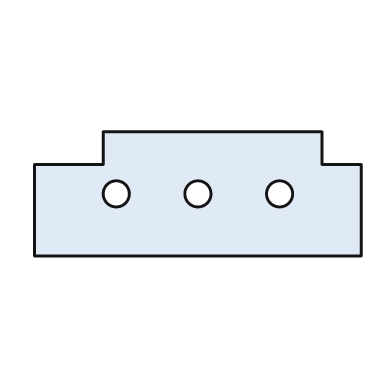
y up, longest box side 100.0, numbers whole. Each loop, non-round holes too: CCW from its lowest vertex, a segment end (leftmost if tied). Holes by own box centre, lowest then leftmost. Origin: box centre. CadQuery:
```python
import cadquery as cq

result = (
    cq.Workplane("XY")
    .moveTo(-50.0, -19.0)
    .lineTo(50.0, -19.0)
    .lineTo(50.0, 9.0)
    .lineTo(38.0, 9.0)
    .lineTo(38.0, 19.0)
    .lineTo(-29.0, 19.0)
    .lineTo(-29.0, 9.0)
    .lineTo(-50.0, 9.0)
    .close()
    .moveTo(-25.0, 0.0)
    .circle(4.0)
    .moveTo(0.0, 0.0)
    .circle(4.0)
    .moveTo(25.0, 0.0)
    .circle(4.0)
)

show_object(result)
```